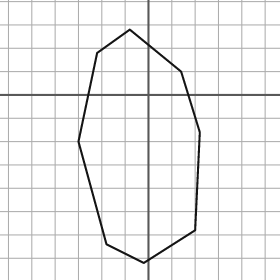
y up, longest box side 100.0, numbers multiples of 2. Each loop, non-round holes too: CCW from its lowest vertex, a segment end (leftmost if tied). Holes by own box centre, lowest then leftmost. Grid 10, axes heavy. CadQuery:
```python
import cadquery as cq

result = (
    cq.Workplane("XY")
    .moveTo(-2.0, -72.0)
    .lineTo(20.0, -58.0)
    .lineTo(22.0, -16.0)
    .lineTo(14.0, 10.0)
    .lineTo(-8.0, 28.0)
    .lineTo(-22.0, 18.0)
    .lineTo(-30.0, -20.0)
    .lineTo(-18.0, -64.0)
    .close()
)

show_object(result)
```